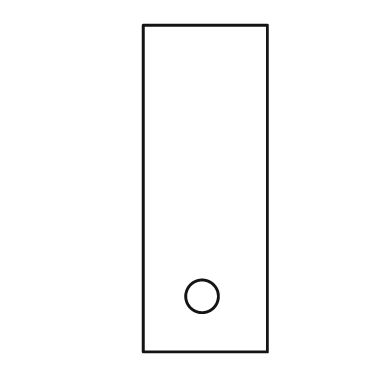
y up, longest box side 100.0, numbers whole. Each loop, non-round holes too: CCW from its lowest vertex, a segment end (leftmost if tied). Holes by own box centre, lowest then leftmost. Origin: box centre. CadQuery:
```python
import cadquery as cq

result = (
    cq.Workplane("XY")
    .moveTo(-19.0, -50.0)
    .lineTo(19.0, -50.0)
    .lineTo(19.0, 50.0)
    .lineTo(-19.0, 50.0)
    .close()
    .moveTo(-1.0, -33.0)
    .circle(5.0)
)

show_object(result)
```